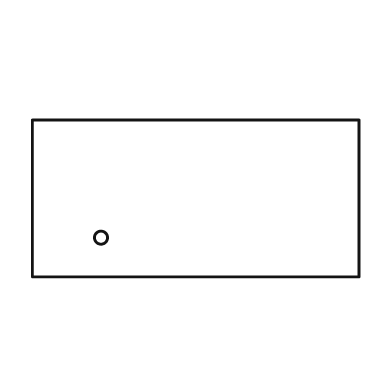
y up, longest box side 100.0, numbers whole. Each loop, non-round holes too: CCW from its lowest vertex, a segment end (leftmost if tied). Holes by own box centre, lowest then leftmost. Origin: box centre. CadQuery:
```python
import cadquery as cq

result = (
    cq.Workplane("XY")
    .moveTo(-50.0, -24.0)
    .lineTo(50.0, -24.0)
    .lineTo(50.0, 24.0)
    .lineTo(-50.0, 24.0)
    .close()
    .moveTo(-29.0, -12.0)
    .circle(2.0)
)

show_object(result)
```